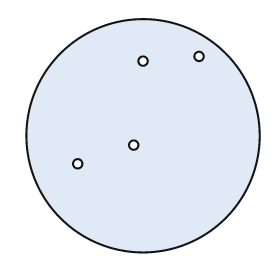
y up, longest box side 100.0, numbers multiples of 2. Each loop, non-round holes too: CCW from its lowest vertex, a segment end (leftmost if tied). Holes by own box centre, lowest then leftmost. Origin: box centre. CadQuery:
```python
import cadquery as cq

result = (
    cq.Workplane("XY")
    .moveTo(0.0, 0.0)
    .circle(50.0)
    .moveTo(-28.0, -12.0)
    .circle(2.0)
    .moveTo(-4.0, -4.0)
    .circle(2.0)
    .moveTo(0.0, 32.0)
    .circle(2.0)
    .moveTo(24.0, 34.0)
    .circle(2.0)
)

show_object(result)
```